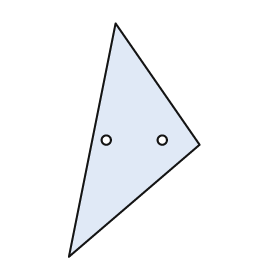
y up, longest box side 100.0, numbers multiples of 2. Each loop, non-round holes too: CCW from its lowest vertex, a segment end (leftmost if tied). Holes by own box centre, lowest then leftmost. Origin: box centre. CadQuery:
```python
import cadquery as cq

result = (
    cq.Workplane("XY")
    .moveTo(-28.0, -50.0)
    .lineTo(28.0, -2.0)
    .lineTo(-8.0, 50.0)
    .close()
    .moveTo(-12.0, 0.0)
    .circle(2.0)
    .moveTo(12.0, 0.0)
    .circle(2.0)
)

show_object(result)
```